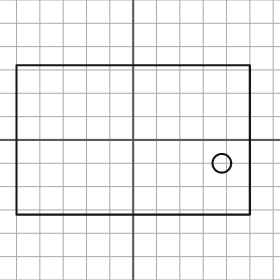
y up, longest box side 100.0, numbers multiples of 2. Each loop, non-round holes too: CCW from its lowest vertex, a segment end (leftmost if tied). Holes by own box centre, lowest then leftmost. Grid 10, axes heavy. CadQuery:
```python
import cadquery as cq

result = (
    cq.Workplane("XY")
    .moveTo(-50.0, -32.0)
    .lineTo(50.0, -32.0)
    .lineTo(50.0, 32.0)
    .lineTo(-50.0, 32.0)
    .close()
    .moveTo(38.0, -10.0)
    .circle(4.0)
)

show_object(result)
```